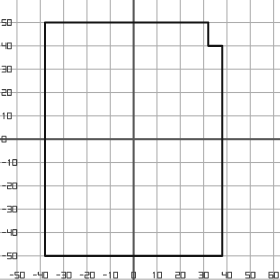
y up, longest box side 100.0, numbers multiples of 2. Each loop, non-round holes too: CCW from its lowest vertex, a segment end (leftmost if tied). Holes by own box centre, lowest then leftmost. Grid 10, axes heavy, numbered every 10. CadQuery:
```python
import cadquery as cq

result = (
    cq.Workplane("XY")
    .moveTo(-38.0, -50.0)
    .lineTo(38.0, -50.0)
    .lineTo(38.0, 40.0)
    .lineTo(32.0, 40.0)
    .lineTo(32.0, 50.0)
    .lineTo(-38.0, 50.0)
    .close()
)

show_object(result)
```